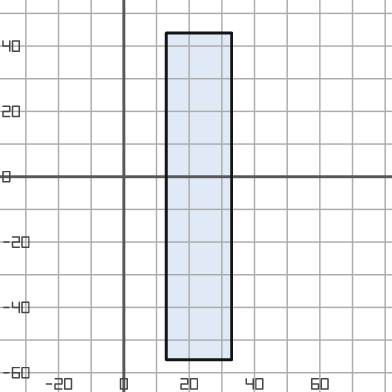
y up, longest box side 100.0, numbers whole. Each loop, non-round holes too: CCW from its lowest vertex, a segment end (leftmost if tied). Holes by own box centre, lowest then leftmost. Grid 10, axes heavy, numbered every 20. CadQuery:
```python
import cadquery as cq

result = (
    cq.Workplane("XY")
    .moveTo(13.0, -56.0)
    .lineTo(33.0, -56.0)
    .lineTo(33.0, 44.0)
    .lineTo(13.0, 44.0)
    .close()
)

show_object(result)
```